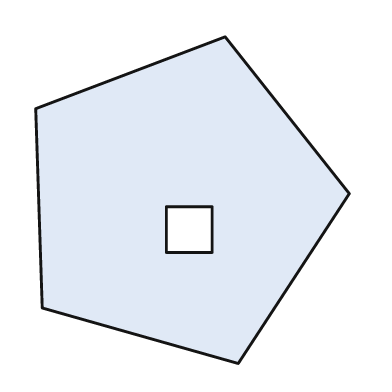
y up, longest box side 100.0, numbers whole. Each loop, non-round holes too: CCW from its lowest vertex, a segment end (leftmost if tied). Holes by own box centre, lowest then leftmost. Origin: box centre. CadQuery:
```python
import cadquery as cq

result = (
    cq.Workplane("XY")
    .moveTo(14.0, -50.0)
    .lineTo(48.0, 2.0)
    .lineTo(10.0, 50.0)
    .lineTo(-48.0, 28.0)
    .lineTo(-46.0, -33.0)
    .close()
    .moveTo(-8.0, -16.0)
    .lineTo(6.0, -16.0)
    .lineTo(6.0, -2.0)
    .lineTo(-8.0, -2.0)
    .close()
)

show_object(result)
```